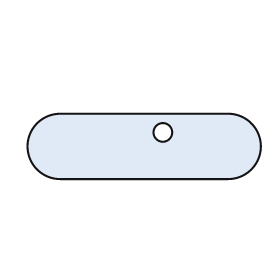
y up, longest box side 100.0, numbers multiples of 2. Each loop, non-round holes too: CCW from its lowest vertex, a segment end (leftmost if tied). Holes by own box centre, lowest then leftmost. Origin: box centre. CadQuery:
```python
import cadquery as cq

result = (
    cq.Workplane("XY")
    .moveTo(-36.0, -14.0)
    .lineTo(36.0, -14.0)
    .threePointArc((50.0, 0.0), (36.0, 14.0))
    .lineTo(-36.0, 14.0)
    .threePointArc((-50.0, 0.0), (-36.0, -14.0))
    .close()
    .moveTo(8.0, 6.0)
    .circle(4.0)
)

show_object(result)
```